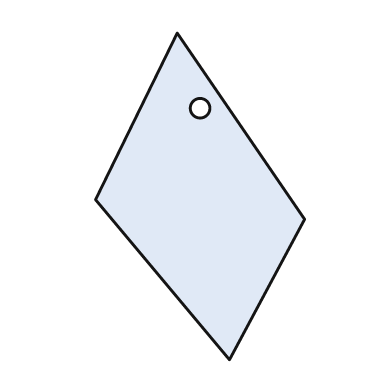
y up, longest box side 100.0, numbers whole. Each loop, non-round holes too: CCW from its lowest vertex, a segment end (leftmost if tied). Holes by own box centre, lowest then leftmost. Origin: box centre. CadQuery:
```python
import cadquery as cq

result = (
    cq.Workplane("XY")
    .moveTo(9.0, -50.0)
    .lineTo(32.0, -7.0)
    .lineTo(-7.0, 50.0)
    .lineTo(-32.0, -1.0)
    .close()
    .moveTo(0.0, 27.0)
    .circle(3.0)
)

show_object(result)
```